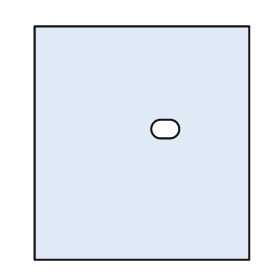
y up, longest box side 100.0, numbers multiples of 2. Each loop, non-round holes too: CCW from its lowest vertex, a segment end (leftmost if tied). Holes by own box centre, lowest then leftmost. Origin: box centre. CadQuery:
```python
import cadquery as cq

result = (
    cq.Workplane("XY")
    .moveTo(-46.0, -50.0)
    .lineTo(46.0, -50.0)
    .lineTo(46.0, 50.0)
    .lineTo(-46.0, 50.0)
    .close()
    .moveTo(8.0, 2.0)
    .lineTo(12.0, 2.0)
    .threePointArc((16.0, 6.0), (12.0, 10.0))
    .lineTo(8.0, 10.0)
    .threePointArc((4.0, 6.0), (8.0, 2.0))
    .close()
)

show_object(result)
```